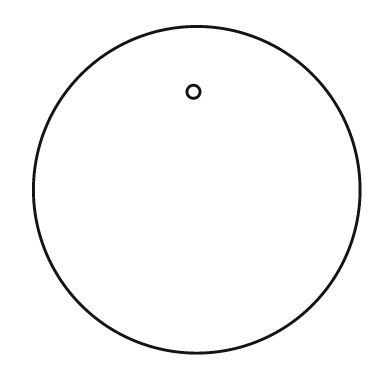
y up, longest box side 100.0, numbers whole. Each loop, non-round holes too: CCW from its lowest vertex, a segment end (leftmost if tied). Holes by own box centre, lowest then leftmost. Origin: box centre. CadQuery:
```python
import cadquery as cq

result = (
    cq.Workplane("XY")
    .moveTo(0.0, 0.0)
    .circle(50.0)
    .moveTo(-1.0, 30.0)
    .circle(2.0)
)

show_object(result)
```